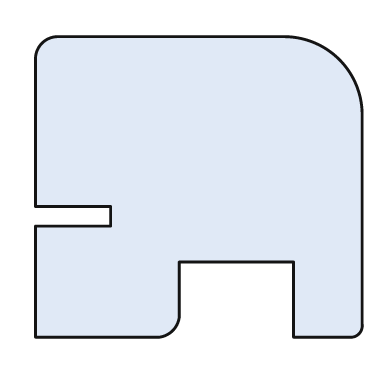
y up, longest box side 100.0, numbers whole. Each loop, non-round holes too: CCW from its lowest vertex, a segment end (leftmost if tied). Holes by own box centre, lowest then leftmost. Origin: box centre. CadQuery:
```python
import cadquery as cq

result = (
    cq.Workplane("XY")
    .moveTo(-50.0, -46.0)
    .lineTo(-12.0, -46.0)
    .threePointArc((-8.0, -44.0), (-6.0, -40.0))
    .lineTo(-6.0, -23.0)
    .lineTo(29.0, -23.0)
    .lineTo(29.0, -46.0)
    .lineTo(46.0, -46.0)
    .threePointArc((49.0, -45.0), (50.0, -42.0))
    .lineTo(50.0, 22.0)
    .threePointArc((43.0, 39.0), (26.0, 46.0))
    .lineTo(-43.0, 46.0)
    .threePointArc((-48.0, 44.0), (-50.0, 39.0))
    .lineTo(-50.0, -6.0)
    .lineTo(-27.0, -6.0)
    .lineTo(-27.0, -12.0)
    .lineTo(-50.0, -12.0)
    .close()
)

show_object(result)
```